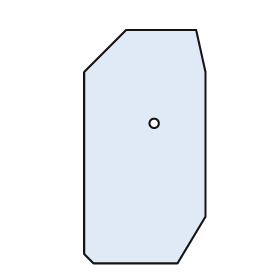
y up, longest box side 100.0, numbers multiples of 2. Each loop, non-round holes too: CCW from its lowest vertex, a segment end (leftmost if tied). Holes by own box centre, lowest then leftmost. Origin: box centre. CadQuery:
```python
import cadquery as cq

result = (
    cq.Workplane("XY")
    .moveTo(-22.0, -50.0)
    .lineTo(14.0, -50.0)
    .lineTo(26.0, -30.0)
    .lineTo(26.0, 32.0)
    .lineTo(22.0, 50.0)
    .lineTo(-8.0, 50.0)
    .lineTo(-26.0, 32.0)
    .lineTo(-26.0, -46.0)
    .close()
    .moveTo(4.0, 10.0)
    .circle(2.0)
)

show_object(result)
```